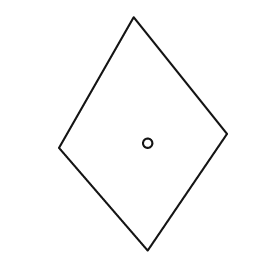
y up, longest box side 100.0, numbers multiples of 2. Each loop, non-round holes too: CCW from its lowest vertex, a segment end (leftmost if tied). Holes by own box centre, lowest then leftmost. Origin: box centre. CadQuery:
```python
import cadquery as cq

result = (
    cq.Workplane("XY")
    .moveTo(2.0, -50.0)
    .lineTo(36.0, 0.0)
    .lineTo(-4.0, 50.0)
    .lineTo(-36.0, -6.0)
    .close()
    .moveTo(2.0, -4.0)
    .circle(2.0)
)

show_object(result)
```